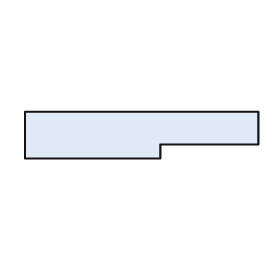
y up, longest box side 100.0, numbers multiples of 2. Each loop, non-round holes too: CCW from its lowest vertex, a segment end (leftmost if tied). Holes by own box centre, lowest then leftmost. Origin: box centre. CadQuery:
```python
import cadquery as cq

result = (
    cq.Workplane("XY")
    .moveTo(-50.0, -10.0)
    .lineTo(8.0, -10.0)
    .lineTo(8.0, -4.0)
    .lineTo(50.0, -4.0)
    .lineTo(50.0, 10.0)
    .lineTo(-50.0, 10.0)
    .close()
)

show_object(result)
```